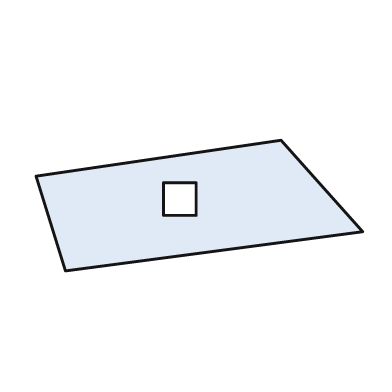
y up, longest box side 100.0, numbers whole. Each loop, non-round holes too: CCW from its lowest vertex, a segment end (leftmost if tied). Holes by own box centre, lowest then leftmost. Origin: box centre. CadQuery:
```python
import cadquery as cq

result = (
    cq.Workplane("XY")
    .moveTo(-41.0, -20.0)
    .lineTo(50.0, -8.0)
    .lineTo(25.0, 20.0)
    .lineTo(-50.0, 9.0)
    .close()
    .moveTo(-11.0, -3.0)
    .lineTo(-1.0, -3.0)
    .lineTo(-1.0, 7.0)
    .lineTo(-11.0, 7.0)
    .close()
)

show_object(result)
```